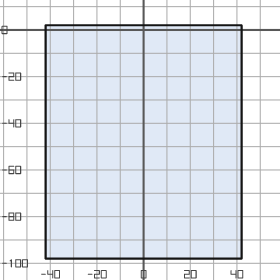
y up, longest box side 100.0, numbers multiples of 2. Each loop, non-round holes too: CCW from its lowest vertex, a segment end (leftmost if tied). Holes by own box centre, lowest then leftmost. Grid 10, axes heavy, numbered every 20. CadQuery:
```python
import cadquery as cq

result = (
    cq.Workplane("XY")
    .moveTo(-42.0, -98.0)
    .lineTo(42.0, -98.0)
    .lineTo(42.0, 2.0)
    .lineTo(-42.0, 2.0)
    .close()
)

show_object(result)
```